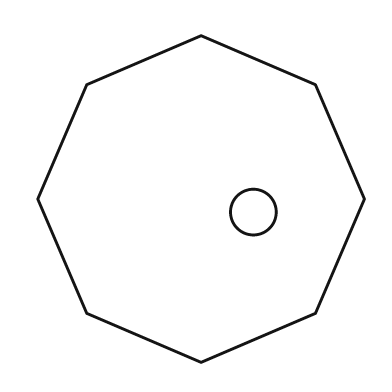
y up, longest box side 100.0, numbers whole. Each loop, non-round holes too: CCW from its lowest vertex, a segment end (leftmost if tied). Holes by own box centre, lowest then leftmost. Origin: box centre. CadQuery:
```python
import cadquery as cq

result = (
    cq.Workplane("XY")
    .moveTo(0.0, -50.0)
    .lineTo(35.0, -35.0)
    .lineTo(50.0, 0.0)
    .lineTo(35.0, 35.0)
    .lineTo(0.0, 50.0)
    .lineTo(-35.0, 35.0)
    .lineTo(-50.0, 0.0)
    .lineTo(-35.0, -35.0)
    .close()
    .moveTo(16.0, -4.0)
    .circle(7.0)
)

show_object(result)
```